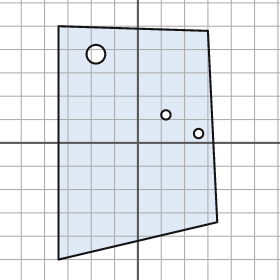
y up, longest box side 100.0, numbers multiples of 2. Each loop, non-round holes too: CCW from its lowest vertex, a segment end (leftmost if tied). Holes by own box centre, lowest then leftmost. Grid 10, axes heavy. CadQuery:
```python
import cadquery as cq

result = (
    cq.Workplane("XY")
    .moveTo(-34.0, -50.0)
    .lineTo(34.0, -34.0)
    .lineTo(30.0, 48.0)
    .lineTo(-34.0, 50.0)
    .close()
    .moveTo(26.0, 4.0)
    .circle(2.0)
    .moveTo(12.0, 12.0)
    .circle(2.0)
    .moveTo(-18.0, 38.0)
    .circle(4.0)
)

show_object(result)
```